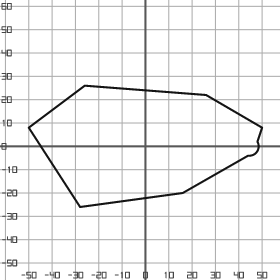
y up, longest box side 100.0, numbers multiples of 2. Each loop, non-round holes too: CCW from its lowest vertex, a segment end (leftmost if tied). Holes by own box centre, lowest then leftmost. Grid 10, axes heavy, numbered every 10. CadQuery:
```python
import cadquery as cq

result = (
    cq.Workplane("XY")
    .moveTo(-28.0, -26.0)
    .lineTo(16.0, -20.0)
    .lineTo(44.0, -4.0)
    .threePointArc((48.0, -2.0), (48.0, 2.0))
    .lineTo(50.0, 8.0)
    .lineTo(26.0, 22.0)
    .lineTo(-26.0, 26.0)
    .lineTo(-50.0, 8.0)
    .close()
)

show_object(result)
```